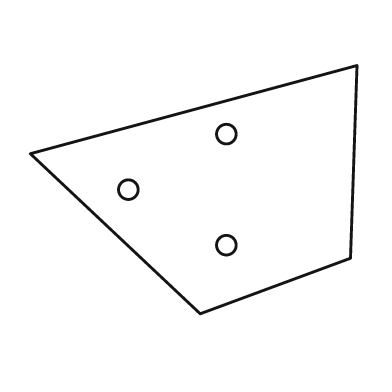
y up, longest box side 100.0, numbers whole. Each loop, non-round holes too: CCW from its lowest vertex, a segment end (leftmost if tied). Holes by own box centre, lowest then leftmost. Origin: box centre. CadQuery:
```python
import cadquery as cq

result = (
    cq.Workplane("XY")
    .moveTo(2.0, -38.0)
    .lineTo(48.0, -21.0)
    .lineTo(50.0, 38.0)
    .lineTo(-50.0, 11.0)
    .close()
    .moveTo(10.0, -17.0)
    .circle(3.0)
    .moveTo(-20.0, 0.0)
    .circle(3.0)
    .moveTo(10.0, 17.0)
    .circle(3.0)
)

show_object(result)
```